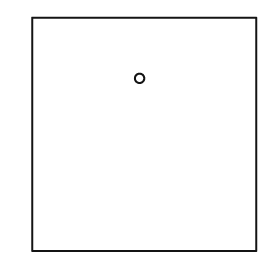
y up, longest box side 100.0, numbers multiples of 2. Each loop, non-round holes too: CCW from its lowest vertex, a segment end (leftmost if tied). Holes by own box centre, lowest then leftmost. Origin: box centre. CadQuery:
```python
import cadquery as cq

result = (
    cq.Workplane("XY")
    .moveTo(-48.0, -50.0)
    .lineTo(48.0, -50.0)
    .lineTo(48.0, 50.0)
    .lineTo(-48.0, 50.0)
    .close()
    .moveTo(-2.0, 24.0)
    .circle(2.0)
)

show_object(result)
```